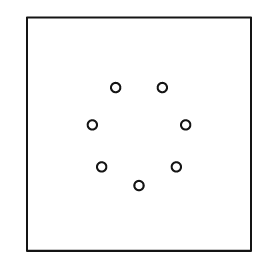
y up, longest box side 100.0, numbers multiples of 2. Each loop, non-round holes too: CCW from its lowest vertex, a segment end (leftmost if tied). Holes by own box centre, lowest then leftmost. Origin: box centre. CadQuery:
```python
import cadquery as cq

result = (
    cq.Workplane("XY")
    .moveTo(-48.0, -50.0)
    .lineTo(48.0, -50.0)
    .lineTo(48.0, 50.0)
    .lineTo(-48.0, 50.0)
    .close()
    .moveTo(0.0, -22.0)
    .circle(2.0)
    .moveTo(-16.0, -14.0)
    .circle(2.0)
    .moveTo(16.0, -14.0)
    .circle(2.0)
    .moveTo(-20.0, 4.0)
    .circle(2.0)
    .moveTo(20.0, 4.0)
    .circle(2.0)
    .moveTo(-10.0, 20.0)
    .circle(2.0)
    .moveTo(10.0, 20.0)
    .circle(2.0)
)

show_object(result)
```